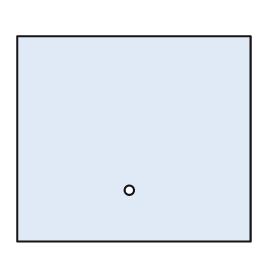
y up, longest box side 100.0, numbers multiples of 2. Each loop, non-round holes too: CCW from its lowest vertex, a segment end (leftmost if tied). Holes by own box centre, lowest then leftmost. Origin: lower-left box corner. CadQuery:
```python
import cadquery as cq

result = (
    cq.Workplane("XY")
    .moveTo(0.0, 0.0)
    .lineTo(100.0, 0.0)
    .lineTo(100.0, 88.0)
    .lineTo(0.0, 88.0)
    .close()
    .moveTo(48.0, 22.0)
    .circle(2.0)
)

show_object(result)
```